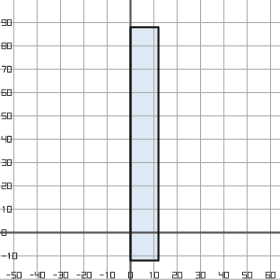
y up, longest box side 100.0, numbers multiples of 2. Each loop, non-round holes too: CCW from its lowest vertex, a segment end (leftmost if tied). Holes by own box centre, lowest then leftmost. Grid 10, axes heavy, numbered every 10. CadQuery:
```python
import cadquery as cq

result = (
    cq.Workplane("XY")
    .moveTo(0.0, -12.0)
    .lineTo(12.0, -12.0)
    .lineTo(12.0, 88.0)
    .lineTo(0.0, 88.0)
    .close()
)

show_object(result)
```